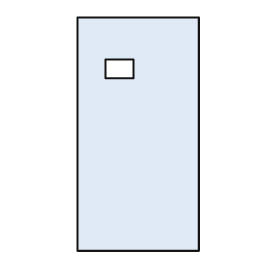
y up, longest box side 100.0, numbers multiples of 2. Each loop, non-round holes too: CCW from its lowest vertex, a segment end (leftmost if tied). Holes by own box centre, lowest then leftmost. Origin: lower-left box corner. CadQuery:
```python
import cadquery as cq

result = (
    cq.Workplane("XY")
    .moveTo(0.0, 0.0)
    .lineTo(52.0, 0.0)
    .lineTo(52.0, 100.0)
    .lineTo(0.0, 100.0)
    .close()
    .moveTo(12.0, 74.0)
    .lineTo(24.0, 74.0)
    .lineTo(24.0, 82.0)
    .lineTo(12.0, 82.0)
    .close()
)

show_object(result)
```